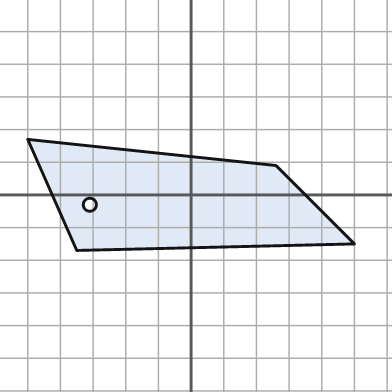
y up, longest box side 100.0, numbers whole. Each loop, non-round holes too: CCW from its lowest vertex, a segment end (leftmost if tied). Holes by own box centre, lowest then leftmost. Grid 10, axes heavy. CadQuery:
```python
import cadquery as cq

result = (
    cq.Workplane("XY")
    .moveTo(-35.0, -17.0)
    .lineTo(50.0, -15.0)
    .lineTo(26.0, 9.0)
    .lineTo(-50.0, 17.0)
    .close()
    .moveTo(-31.0, -3.0)
    .circle(2.0)
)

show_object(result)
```